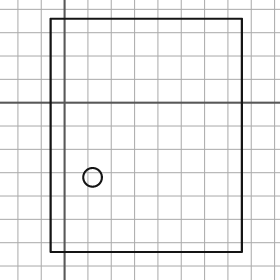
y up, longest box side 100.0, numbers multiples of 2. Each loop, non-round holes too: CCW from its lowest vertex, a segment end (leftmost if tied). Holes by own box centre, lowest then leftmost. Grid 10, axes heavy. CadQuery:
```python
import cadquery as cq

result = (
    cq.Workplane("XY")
    .moveTo(-6.0, -64.0)
    .lineTo(76.0, -64.0)
    .lineTo(76.0, 36.0)
    .lineTo(-6.0, 36.0)
    .close()
    .moveTo(12.0, -32.0)
    .circle(4.0)
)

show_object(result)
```